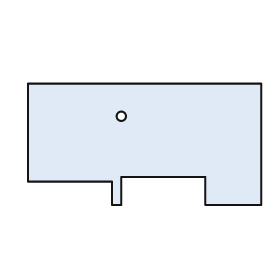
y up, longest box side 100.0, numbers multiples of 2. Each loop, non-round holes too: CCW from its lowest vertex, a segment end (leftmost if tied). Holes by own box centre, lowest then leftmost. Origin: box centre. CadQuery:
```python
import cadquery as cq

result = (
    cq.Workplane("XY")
    .moveTo(-14.0, -26.0)
    .lineTo(-10.0, -26.0)
    .lineTo(-10.0, -14.0)
    .lineTo(26.0, -14.0)
    .lineTo(26.0, -26.0)
    .lineTo(50.0, -26.0)
    .lineTo(50.0, 26.0)
    .lineTo(-50.0, 26.0)
    .lineTo(-50.0, -16.0)
    .lineTo(-14.0, -16.0)
    .close()
    .moveTo(-10.0, 12.0)
    .circle(2.0)
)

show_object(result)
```